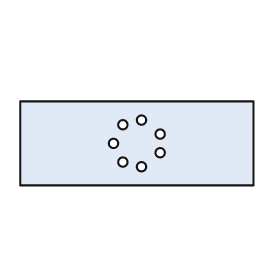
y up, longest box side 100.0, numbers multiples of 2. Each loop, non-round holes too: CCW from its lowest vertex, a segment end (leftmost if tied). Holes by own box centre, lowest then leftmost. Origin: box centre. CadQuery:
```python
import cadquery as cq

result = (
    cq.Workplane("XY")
    .moveTo(-50.0, -18.0)
    .lineTo(50.0, -18.0)
    .lineTo(50.0, 18.0)
    .lineTo(-50.0, 18.0)
    .close()
    .moveTo(2.0, -10.0)
    .circle(2.0)
    .moveTo(-6.0, -8.0)
    .circle(2.0)
    .moveTo(10.0, -4.0)
    .circle(2.0)
    .moveTo(-10.0, 0.0)
    .circle(2.0)
    .moveTo(10.0, 4.0)
    .circle(2.0)
    .moveTo(-6.0, 8.0)
    .circle(2.0)
    .moveTo(2.0, 10.0)
    .circle(2.0)
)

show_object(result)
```